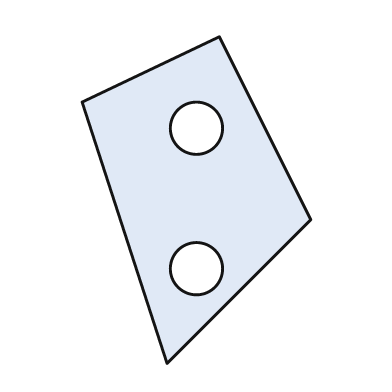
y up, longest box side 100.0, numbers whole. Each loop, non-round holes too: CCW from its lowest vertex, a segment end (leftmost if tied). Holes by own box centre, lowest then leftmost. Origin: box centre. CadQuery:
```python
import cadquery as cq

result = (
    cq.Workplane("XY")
    .moveTo(-9.0, -50.0)
    .lineTo(35.0, -6.0)
    .lineTo(7.0, 50.0)
    .lineTo(-35.0, 30.0)
    .close()
    .moveTo(0.0, -21.0)
    .circle(8.0)
    .moveTo(0.0, 22.0)
    .circle(8.0)
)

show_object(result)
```